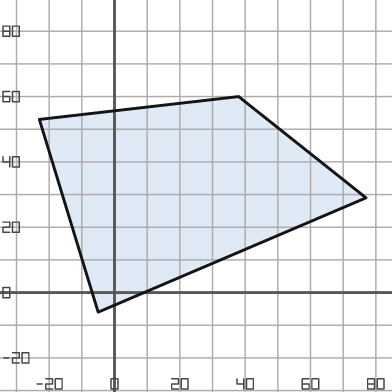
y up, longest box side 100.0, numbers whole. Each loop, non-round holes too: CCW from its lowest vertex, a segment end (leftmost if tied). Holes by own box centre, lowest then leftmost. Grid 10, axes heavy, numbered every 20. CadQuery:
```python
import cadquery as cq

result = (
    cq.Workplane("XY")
    .moveTo(-5.0, -6.0)
    .lineTo(77.0, 29.0)
    .lineTo(38.0, 60.0)
    .lineTo(-23.0, 53.0)
    .close()
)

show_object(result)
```